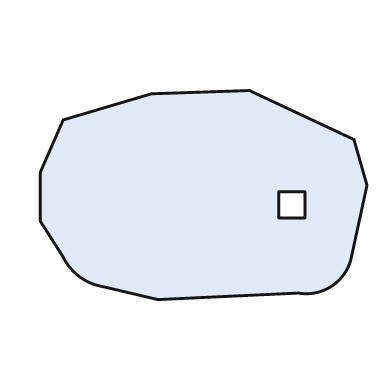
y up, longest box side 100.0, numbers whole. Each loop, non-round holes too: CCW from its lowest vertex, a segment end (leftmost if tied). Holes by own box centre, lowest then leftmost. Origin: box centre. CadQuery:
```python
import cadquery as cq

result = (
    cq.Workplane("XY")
    .moveTo(-14.0, -32.0)
    .lineTo(29.0, -30.0)
    .threePointArc((39.0, -28.0), (45.0, -20.0))
    .lineTo(50.0, 3.0)
    .lineTo(46.0, 17.0)
    .lineTo(14.0, 32.0)
    .lineTo(-16.0, 31.0)
    .lineTo(-43.0, 23.0)
    .lineTo(-50.0, 7.0)
    .lineTo(-50.0, -8.0)
    .lineTo(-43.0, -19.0)
    .threePointArc((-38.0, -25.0), (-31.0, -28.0))
    .close()
    .moveTo(23.0, -7.0)
    .lineTo(31.0, -7.0)
    .lineTo(31.0, 1.0)
    .lineTo(23.0, 1.0)
    .close()
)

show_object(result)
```